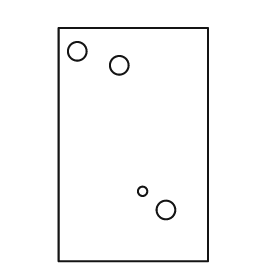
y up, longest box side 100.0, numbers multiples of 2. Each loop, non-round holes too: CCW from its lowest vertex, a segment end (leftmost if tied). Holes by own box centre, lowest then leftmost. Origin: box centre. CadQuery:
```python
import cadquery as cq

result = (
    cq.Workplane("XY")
    .moveTo(-32.0, -50.0)
    .lineTo(32.0, -50.0)
    .lineTo(32.0, 50.0)
    .lineTo(-32.0, 50.0)
    .close()
    .moveTo(14.0, -28.0)
    .circle(4.0)
    .moveTo(4.0, -20.0)
    .circle(2.0)
    .moveTo(-6.0, 34.0)
    .circle(4.0)
    .moveTo(-24.0, 40.0)
    .circle(4.0)
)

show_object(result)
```